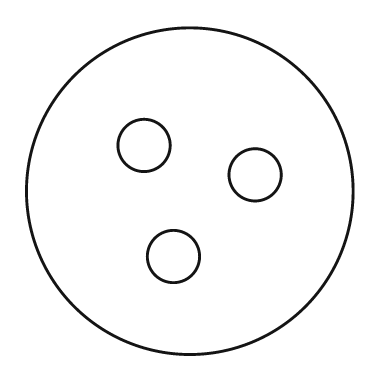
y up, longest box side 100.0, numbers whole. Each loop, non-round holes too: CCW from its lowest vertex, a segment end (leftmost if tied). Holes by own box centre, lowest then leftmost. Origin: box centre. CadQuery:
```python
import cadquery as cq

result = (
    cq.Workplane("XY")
    .moveTo(0.0, 0.0)
    .circle(50.0)
    .moveTo(-5.0, -20.0)
    .circle(8.0)
    .moveTo(20.0, 5.0)
    .circle(8.0)
    .moveTo(-14.0, 14.0)
    .circle(8.0)
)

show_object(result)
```